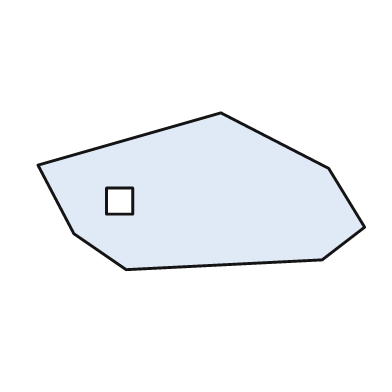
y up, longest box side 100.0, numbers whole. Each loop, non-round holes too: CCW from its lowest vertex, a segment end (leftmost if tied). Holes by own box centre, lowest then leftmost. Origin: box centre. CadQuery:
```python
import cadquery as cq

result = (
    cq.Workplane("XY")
    .moveTo(-23.0, -24.0)
    .lineTo(37.0, -21.0)
    .lineTo(50.0, -11.0)
    .lineTo(39.0, 7.0)
    .lineTo(6.0, 24.0)
    .lineTo(-50.0, 8.0)
    .lineTo(-39.0, -13.0)
    .close()
    .moveTo(-29.0, -7.0)
    .lineTo(-21.0, -7.0)
    .lineTo(-21.0, 1.0)
    .lineTo(-29.0, 1.0)
    .close()
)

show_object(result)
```